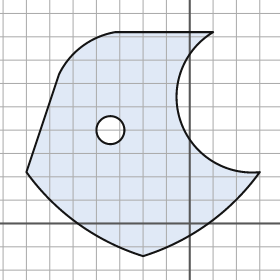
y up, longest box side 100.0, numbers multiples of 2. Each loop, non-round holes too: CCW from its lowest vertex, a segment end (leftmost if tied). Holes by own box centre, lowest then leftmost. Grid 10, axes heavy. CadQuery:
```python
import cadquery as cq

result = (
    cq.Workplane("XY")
    .moveTo(-20.0, -14.0)
    .threePointArc((8.0, 0.0), (30.0, 22.0))
    .threePointArc((-4.0, 44.0), (10.0, 82.0))
    .lineTo(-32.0, 82.0)
    .threePointArc((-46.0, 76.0), (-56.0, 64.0))
    .lineTo(-70.0, 22.0)
    .threePointArc((-48.0, 0.0), (-20.0, -14.0))
    .close()
    .moveTo(-34.0, 40.0)
    .circle(6.0)
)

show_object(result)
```